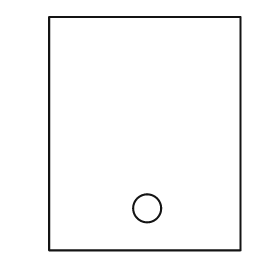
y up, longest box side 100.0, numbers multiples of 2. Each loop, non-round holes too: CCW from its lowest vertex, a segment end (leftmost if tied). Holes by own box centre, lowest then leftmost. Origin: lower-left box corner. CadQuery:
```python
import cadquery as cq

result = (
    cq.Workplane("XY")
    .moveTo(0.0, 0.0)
    .lineTo(82.0, 0.0)
    .lineTo(82.0, 100.0)
    .lineTo(0.0, 100.0)
    .close()
    .moveTo(42.0, 18.0)
    .circle(6.0)
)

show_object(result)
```